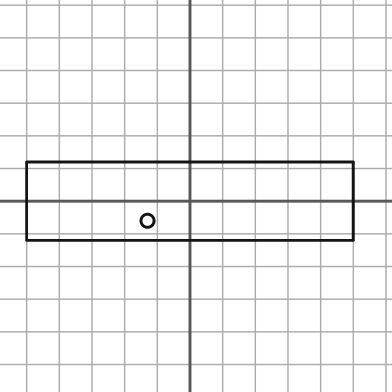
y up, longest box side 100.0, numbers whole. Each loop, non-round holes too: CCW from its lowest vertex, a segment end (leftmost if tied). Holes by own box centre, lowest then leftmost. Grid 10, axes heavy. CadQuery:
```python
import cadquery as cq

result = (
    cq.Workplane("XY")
    .moveTo(-50.0, -12.0)
    .lineTo(50.0, -12.0)
    .lineTo(50.0, 12.0)
    .lineTo(-50.0, 12.0)
    .close()
    .moveTo(-13.0, -6.0)
    .circle(2.0)
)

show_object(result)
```